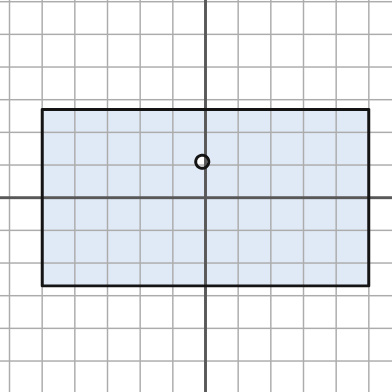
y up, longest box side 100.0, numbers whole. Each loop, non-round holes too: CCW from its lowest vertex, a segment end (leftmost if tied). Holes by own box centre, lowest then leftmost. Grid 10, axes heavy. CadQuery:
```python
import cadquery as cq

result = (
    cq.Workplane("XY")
    .moveTo(-50.0, -27.0)
    .lineTo(50.0, -27.0)
    .lineTo(50.0, 27.0)
    .lineTo(-50.0, 27.0)
    .close()
    .moveTo(-1.0, 11.0)
    .circle(2.0)
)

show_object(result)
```